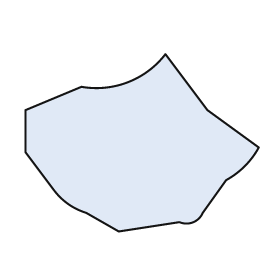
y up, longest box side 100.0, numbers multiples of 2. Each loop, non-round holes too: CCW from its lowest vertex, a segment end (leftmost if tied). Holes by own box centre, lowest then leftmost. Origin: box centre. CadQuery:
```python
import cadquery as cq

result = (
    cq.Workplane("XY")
    .moveTo(-10.0, -38.0)
    .lineTo(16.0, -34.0)
    .threePointArc((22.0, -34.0), (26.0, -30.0))
    .lineTo(36.0, -16.0)
    .threePointArc((44.0, -10.0), (50.0, -2.0))
    .lineTo(28.0, 14.0)
    .lineTo(10.0, 38.0)
    .threePointArc((-6.0, 26.0), (-26.0, 24.0))
    .lineTo(-50.0, 14.0)
    .lineTo(-50.0, -4.0)
    .lineTo(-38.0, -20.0)
    .threePointArc((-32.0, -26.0), (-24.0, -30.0))
    .close()
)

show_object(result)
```